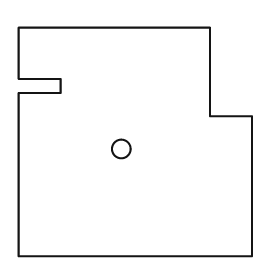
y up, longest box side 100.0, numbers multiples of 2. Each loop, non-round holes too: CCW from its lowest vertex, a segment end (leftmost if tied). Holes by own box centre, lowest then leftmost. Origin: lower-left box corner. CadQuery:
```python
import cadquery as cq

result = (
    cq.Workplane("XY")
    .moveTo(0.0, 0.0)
    .lineTo(100.0, 0.0)
    .lineTo(100.0, 60.0)
    .lineTo(82.0, 60.0)
    .lineTo(82.0, 98.0)
    .lineTo(0.0, 98.0)
    .lineTo(0.0, 76.0)
    .lineTo(18.0, 76.0)
    .lineTo(18.0, 70.0)
    .lineTo(0.0, 70.0)
    .close()
    .moveTo(44.0, 46.0)
    .circle(4.0)
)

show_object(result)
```